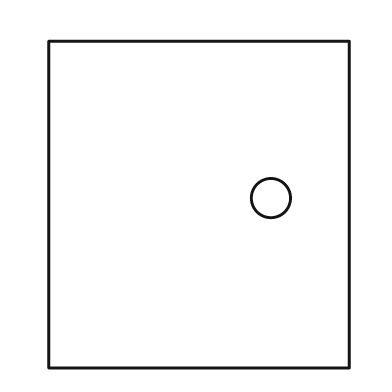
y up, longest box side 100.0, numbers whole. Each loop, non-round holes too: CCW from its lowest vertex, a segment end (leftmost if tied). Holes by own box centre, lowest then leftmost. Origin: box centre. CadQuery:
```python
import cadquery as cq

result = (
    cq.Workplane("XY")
    .moveTo(-46.0, -50.0)
    .lineTo(46.0, -50.0)
    .lineTo(46.0, 50.0)
    .lineTo(-46.0, 50.0)
    .close()
    .moveTo(22.0, 2.0)
    .circle(6.0)
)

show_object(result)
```